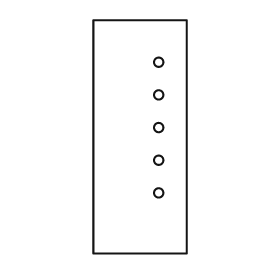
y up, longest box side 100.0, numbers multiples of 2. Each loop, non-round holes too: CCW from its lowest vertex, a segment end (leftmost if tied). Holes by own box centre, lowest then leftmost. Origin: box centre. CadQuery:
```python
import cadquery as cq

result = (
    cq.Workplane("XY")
    .moveTo(-20.0, -50.0)
    .lineTo(20.0, -50.0)
    .lineTo(20.0, 50.0)
    .lineTo(-20.0, 50.0)
    .close()
    .moveTo(8.0, -24.0)
    .circle(2.0)
    .moveTo(8.0, -10.0)
    .circle(2.0)
    .moveTo(8.0, 4.0)
    .circle(2.0)
    .moveTo(8.0, 18.0)
    .circle(2.0)
    .moveTo(8.0, 32.0)
    .circle(2.0)
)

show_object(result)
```